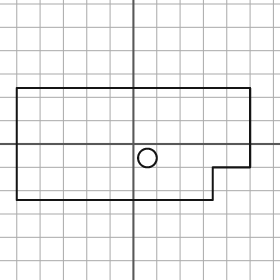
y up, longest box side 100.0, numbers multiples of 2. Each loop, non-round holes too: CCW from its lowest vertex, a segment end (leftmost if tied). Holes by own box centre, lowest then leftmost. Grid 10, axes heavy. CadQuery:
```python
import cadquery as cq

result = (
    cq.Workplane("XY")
    .moveTo(-50.0, -24.0)
    .lineTo(34.0, -24.0)
    .lineTo(34.0, -10.0)
    .lineTo(50.0, -10.0)
    .lineTo(50.0, 24.0)
    .lineTo(-50.0, 24.0)
    .close()
    .moveTo(6.0, -6.0)
    .circle(4.0)
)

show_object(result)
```